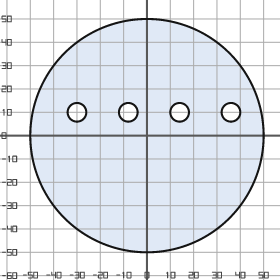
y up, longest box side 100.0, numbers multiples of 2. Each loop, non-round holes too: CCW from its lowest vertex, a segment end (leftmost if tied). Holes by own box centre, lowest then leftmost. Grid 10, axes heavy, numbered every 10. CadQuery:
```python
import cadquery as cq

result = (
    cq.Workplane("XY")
    .moveTo(0.0, 0.0)
    .circle(50.0)
    .moveTo(-30.0, 10.0)
    .circle(4.0)
    .moveTo(-8.0, 10.0)
    .circle(4.0)
    .moveTo(14.0, 10.0)
    .circle(4.0)
    .moveTo(36.0, 10.0)
    .circle(4.0)
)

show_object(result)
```